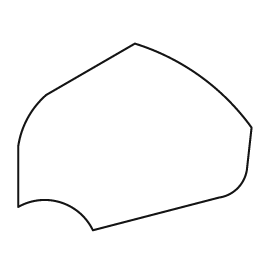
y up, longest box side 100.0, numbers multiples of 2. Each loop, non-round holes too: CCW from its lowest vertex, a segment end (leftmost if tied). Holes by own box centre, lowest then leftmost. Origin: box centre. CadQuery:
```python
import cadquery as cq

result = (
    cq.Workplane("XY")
    .moveTo(-18.0, -40.0)
    .lineTo(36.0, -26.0)
    .threePointArc((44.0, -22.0), (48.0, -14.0))
    .lineTo(50.0, 4.0)
    .threePointArc((28.0, 26.0), (0.0, 40.0))
    .lineTo(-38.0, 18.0)
    .threePointArc((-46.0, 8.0), (-50.0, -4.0))
    .lineTo(-50.0, -30.0)
    .threePointArc((-32.0, -28.0), (-18.0, -40.0))
    .close()
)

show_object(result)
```